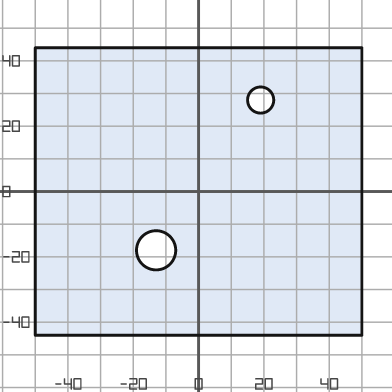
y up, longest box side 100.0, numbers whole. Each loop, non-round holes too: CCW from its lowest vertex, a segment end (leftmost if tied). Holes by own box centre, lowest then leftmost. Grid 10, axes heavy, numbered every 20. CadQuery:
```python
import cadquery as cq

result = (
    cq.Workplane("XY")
    .moveTo(-50.0, -44.0)
    .lineTo(50.0, -44.0)
    .lineTo(50.0, 44.0)
    .lineTo(-50.0, 44.0)
    .close()
    .moveTo(-13.0, -18.0)
    .circle(6.0)
    .moveTo(19.0, 28.0)
    .circle(4.0)
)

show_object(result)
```